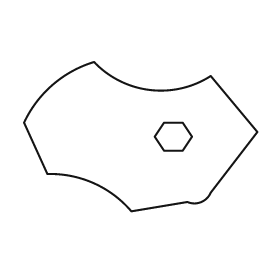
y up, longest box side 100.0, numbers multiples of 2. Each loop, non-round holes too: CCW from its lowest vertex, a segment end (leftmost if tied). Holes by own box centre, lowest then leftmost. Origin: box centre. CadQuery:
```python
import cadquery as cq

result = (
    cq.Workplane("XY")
    .moveTo(-4.0, -32.0)
    .lineTo(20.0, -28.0)
    .threePointArc((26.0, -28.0), (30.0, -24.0))
    .lineTo(50.0, 2.0)
    .lineTo(30.0, 26.0)
    .threePointArc((4.0, 20.0), (-20.0, 32.0))
    .threePointArc((-38.0, 22.0), (-50.0, 6.0))
    .lineTo(-40.0, -16.0)
    .threePointArc((-20.0, -20.0), (-4.0, -32.0))
    .close()
    .moveTo(10.0, -6.0)
    .lineTo(18.0, -6.0)
    .lineTo(22.0, 0.0)
    .lineTo(18.0, 6.0)
    .lineTo(10.0, 6.0)
    .lineTo(6.0, 0.0)
    .close()
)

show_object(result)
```